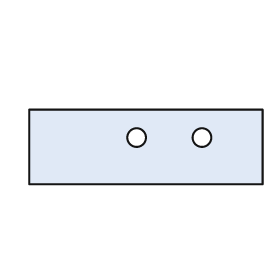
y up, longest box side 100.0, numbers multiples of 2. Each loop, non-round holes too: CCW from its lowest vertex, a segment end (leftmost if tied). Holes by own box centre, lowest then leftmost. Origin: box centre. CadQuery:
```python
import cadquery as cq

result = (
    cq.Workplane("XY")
    .moveTo(-50.0, -16.0)
    .lineTo(50.0, -16.0)
    .lineTo(50.0, 16.0)
    .lineTo(-50.0, 16.0)
    .close()
    .moveTo(-4.0, 4.0)
    .circle(4.0)
    .moveTo(24.0, 4.0)
    .circle(4.0)
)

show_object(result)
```